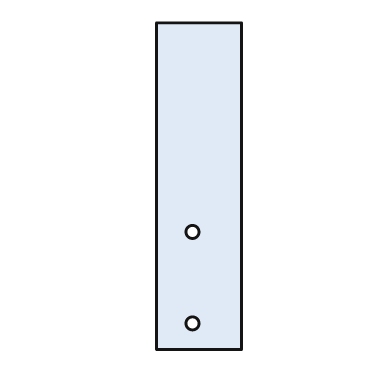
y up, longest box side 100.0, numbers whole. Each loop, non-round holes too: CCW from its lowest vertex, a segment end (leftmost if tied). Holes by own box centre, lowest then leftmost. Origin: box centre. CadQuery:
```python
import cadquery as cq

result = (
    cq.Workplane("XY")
    .moveTo(-13.0, -50.0)
    .lineTo(13.0, -50.0)
    .lineTo(13.0, 50.0)
    .lineTo(-13.0, 50.0)
    .close()
    .moveTo(-2.0, -42.0)
    .circle(2.0)
    .moveTo(-2.0, -14.0)
    .circle(2.0)
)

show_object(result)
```